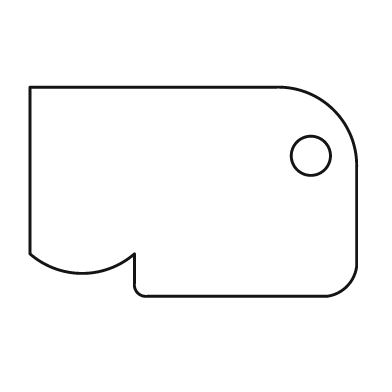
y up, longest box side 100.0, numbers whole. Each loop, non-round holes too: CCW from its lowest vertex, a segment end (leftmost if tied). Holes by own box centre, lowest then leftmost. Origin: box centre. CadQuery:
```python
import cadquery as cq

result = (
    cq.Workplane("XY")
    .moveTo(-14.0, -32.0)
    .lineTo(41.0, -32.0)
    .threePointArc((47.0, -29.0), (50.0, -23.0))
    .lineTo(50.0, 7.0)
    .threePointArc((43.0, 25.0), (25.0, 32.0))
    .lineTo(-50.0, 32.0)
    .lineTo(-50.0, -19.0)
    .threePointArc((-34.0, -25.0), (-18.0, -19.0))
    .lineTo(-18.0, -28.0)
    .threePointArc((-17.0, -31.0), (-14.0, -32.0))
    .close()
    .moveTo(36.0, 11.0)
    .circle(6.0)
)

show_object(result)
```